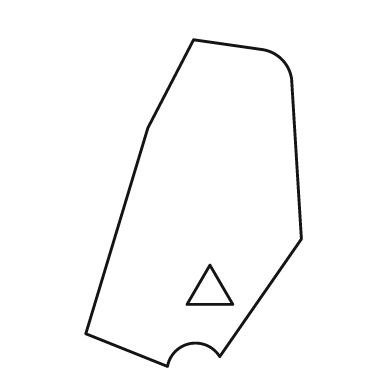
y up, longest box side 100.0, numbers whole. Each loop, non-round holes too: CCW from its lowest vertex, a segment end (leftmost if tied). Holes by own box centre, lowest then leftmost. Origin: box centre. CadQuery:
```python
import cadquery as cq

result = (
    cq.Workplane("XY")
    .moveTo(-8.0, -50.0)
    .threePointArc((-1.0, -43.0), (8.0, -47.0))
    .lineTo(33.0, -11.0)
    .lineTo(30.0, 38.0)
    .threePointArc((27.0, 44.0), (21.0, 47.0))
    .lineTo(0.0, 50.0)
    .lineTo(-14.0, 23.0)
    .lineTo(-33.0, -40.0)
    .close()
    .moveTo(-2.0, -31.0)
    .lineTo(12.0, -31.0)
    .lineTo(5.0, -19.0)
    .close()
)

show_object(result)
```